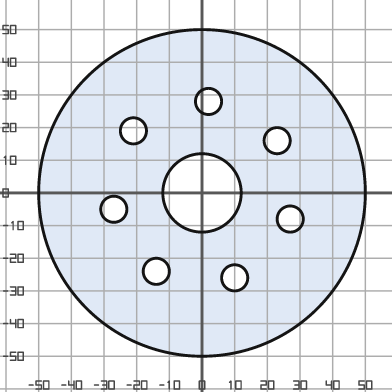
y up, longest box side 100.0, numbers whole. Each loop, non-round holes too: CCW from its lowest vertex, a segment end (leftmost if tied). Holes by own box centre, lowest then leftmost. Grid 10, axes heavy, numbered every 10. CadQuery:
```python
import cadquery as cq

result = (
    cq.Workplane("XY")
    .moveTo(0.0, 0.0)
    .circle(50.0)
    .moveTo(10.0, -26.0)
    .circle(4.0)
    .moveTo(-14.0, -24.0)
    .circle(4.0)
    .moveTo(27.0, -8.0)
    .circle(4.0)
    .moveTo(-27.0, -5.0)
    .circle(4.0)
    .moveTo(0.0, 0.0)
    .circle(12.0)
    .moveTo(23.0, 16.0)
    .circle(4.0)
    .moveTo(-21.0, 19.0)
    .circle(4.0)
    .moveTo(2.0, 28.0)
    .circle(4.0)
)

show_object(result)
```